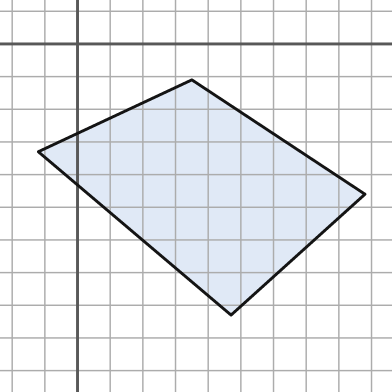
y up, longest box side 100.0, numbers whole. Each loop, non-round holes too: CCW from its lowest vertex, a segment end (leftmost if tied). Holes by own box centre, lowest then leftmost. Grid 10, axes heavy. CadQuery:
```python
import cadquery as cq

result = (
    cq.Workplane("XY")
    .moveTo(47.0, -83.0)
    .lineTo(88.0, -46.0)
    .lineTo(35.0, -11.0)
    .lineTo(-12.0, -33.0)
    .close()
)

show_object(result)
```